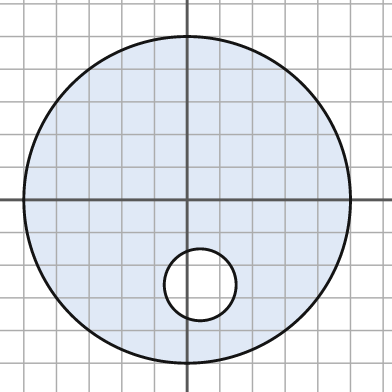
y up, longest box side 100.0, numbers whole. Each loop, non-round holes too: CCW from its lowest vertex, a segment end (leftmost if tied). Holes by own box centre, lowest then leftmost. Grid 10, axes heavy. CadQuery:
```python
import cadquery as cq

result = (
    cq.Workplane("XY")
    .moveTo(0.0, 0.0)
    .circle(50.0)
    .moveTo(4.0, -26.0)
    .circle(11.0)
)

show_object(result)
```